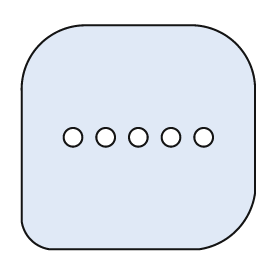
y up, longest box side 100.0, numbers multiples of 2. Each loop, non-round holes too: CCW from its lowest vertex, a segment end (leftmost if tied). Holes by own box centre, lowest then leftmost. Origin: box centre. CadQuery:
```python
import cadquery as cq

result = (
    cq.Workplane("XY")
    .moveTo(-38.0, -48.0)
    .lineTo(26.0, -48.0)
    .threePointArc((42.0, -40.0), (50.0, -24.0))
    .lineTo(50.0, 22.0)
    .threePointArc((42.0, 40.0), (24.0, 48.0))
    .lineTo(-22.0, 48.0)
    .threePointArc((-42.0, 40.0), (-50.0, 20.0))
    .lineTo(-50.0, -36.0)
    .threePointArc((-46.0, -44.0), (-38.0, -48.0))
    .close()
    .moveTo(-28.0, 0.0)
    .circle(4.0)
    .moveTo(-14.0, 0.0)
    .circle(4.0)
    .moveTo(0.0, 0.0)
    .circle(4.0)
    .moveTo(14.0, 0.0)
    .circle(4.0)
    .moveTo(28.0, 0.0)
    .circle(4.0)
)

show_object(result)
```